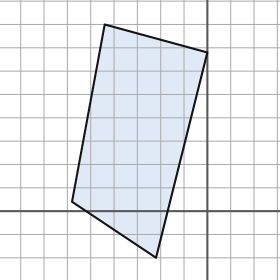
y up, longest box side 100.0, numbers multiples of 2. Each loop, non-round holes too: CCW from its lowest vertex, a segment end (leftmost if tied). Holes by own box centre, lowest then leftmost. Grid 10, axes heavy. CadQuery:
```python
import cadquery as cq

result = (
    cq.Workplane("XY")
    .moveTo(-22.0, -20.0)
    .lineTo(0.0, 68.0)
    .lineTo(-44.0, 80.0)
    .lineTo(-58.0, 4.0)
    .close()
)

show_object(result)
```